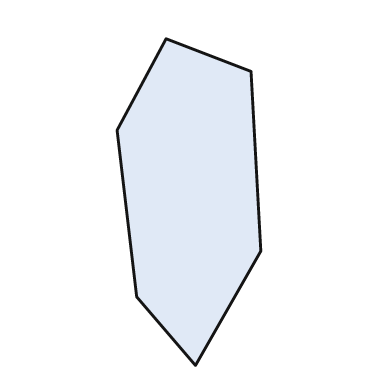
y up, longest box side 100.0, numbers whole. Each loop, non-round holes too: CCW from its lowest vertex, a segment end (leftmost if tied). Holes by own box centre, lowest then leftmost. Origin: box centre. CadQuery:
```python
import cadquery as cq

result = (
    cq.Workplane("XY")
    .moveTo(2.0, -50.0)
    .lineTo(22.0, -15.0)
    .lineTo(19.0, 40.0)
    .lineTo(-7.0, 50.0)
    .lineTo(-22.0, 22.0)
    .lineTo(-16.0, -29.0)
    .close()
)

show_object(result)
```